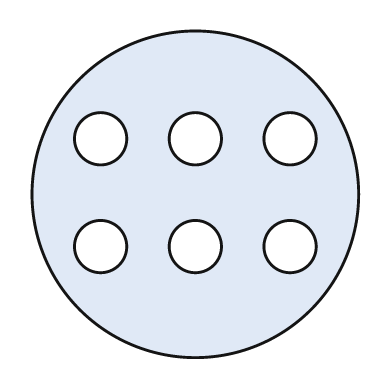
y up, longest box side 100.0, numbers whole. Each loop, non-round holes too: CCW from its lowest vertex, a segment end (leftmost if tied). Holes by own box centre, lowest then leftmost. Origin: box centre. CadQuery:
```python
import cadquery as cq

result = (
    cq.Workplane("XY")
    .moveTo(0.0, 0.0)
    .circle(50.0)
    .moveTo(-29.0, -16.0)
    .circle(8.0)
    .moveTo(0.0, -16.0)
    .circle(8.0)
    .moveTo(29.0, -16.0)
    .circle(8.0)
    .moveTo(-29.0, 17.0)
    .circle(8.0)
    .moveTo(0.0, 17.0)
    .circle(8.0)
    .moveTo(29.0, 17.0)
    .circle(8.0)
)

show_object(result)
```